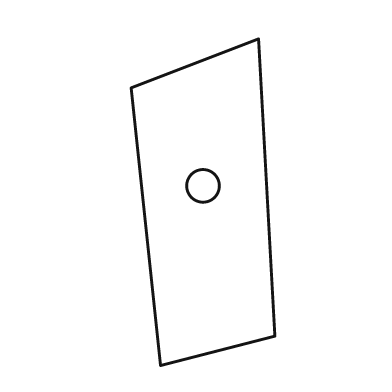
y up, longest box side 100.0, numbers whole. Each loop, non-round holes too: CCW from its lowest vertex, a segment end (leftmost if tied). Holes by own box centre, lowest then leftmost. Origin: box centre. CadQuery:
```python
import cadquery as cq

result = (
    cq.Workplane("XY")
    .moveTo(-13.0, -50.0)
    .lineTo(22.0, -41.0)
    .lineTo(17.0, 50.0)
    .lineTo(-22.0, 35.0)
    .close()
    .moveTo(0.0, 5.0)
    .circle(5.0)
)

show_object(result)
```